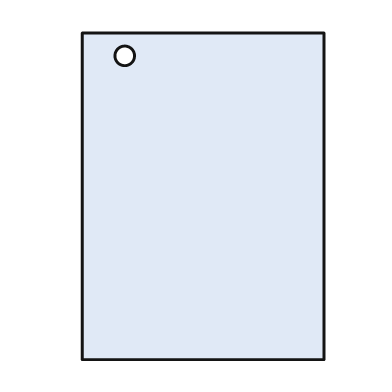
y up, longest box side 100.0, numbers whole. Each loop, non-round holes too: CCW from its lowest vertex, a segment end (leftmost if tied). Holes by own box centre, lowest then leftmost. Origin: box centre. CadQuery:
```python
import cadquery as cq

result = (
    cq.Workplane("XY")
    .moveTo(-37.0, -50.0)
    .lineTo(37.0, -50.0)
    .lineTo(37.0, 50.0)
    .lineTo(-37.0, 50.0)
    .close()
    .moveTo(-24.0, 43.0)
    .circle(3.0)
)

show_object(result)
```